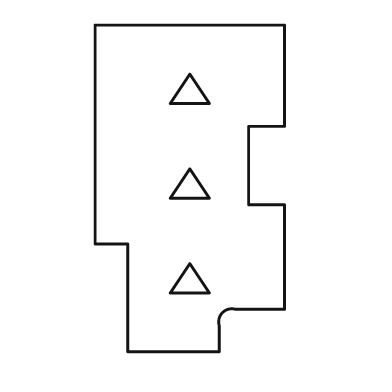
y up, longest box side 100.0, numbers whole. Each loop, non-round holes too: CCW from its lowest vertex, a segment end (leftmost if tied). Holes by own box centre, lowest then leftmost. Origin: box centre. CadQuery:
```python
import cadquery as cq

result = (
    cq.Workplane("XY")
    .moveTo(-19.0, -50.0)
    .lineTo(9.0, -50.0)
    .lineTo(9.0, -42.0)
    .threePointArc((10.0, -38.0), (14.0, -37.0))
    .lineTo(29.0, -37.0)
    .lineTo(29.0, -5.0)
    .lineTo(18.0, -5.0)
    .lineTo(18.0, 19.0)
    .lineTo(29.0, 19.0)
    .lineTo(29.0, 50.0)
    .lineTo(-29.0, 50.0)
    .lineTo(-29.0, -17.0)
    .lineTo(-19.0, -17.0)
    .close()
    .moveTo(-6.0, -32.0)
    .lineTo(6.0, -32.0)
    .lineTo(0.0, -23.0)
    .close()
    .moveTo(-6.0, -3.0)
    .lineTo(6.0, -3.0)
    .lineTo(0.0, 6.0)
    .close()
    .moveTo(-6.0, 26.0)
    .lineTo(6.0, 26.0)
    .lineTo(0.0, 35.0)
    .close()
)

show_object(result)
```